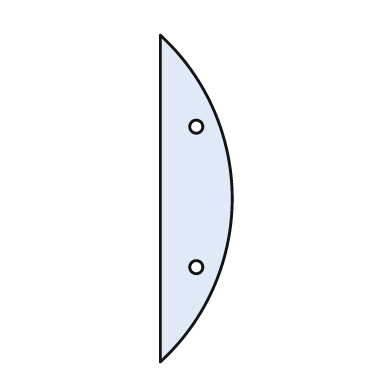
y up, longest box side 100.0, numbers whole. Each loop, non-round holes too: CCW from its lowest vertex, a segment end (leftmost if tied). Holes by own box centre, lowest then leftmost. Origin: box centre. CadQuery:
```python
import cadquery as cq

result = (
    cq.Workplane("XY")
    .moveTo(-11.0, -50.0)
    .threePointArc((11.0, 0.0), (-11.0, 50.0))
    .close()
    .moveTo(0.0, -21.0)
    .circle(2.0)
    .moveTo(0.0, 22.0)
    .circle(2.0)
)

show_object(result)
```